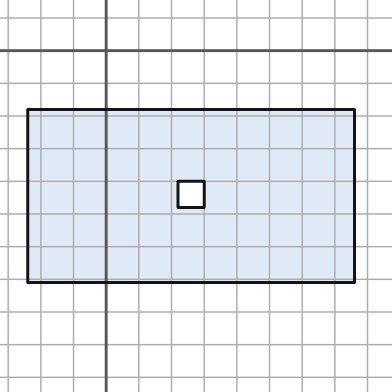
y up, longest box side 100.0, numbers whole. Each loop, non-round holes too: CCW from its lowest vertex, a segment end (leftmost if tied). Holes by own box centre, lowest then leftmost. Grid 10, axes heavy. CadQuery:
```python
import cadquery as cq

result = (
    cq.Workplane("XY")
    .moveTo(-24.0, -71.0)
    .lineTo(76.0, -71.0)
    .lineTo(76.0, -18.0)
    .lineTo(-24.0, -18.0)
    .close()
    .moveTo(22.0, -48.0)
    .lineTo(30.0, -48.0)
    .lineTo(30.0, -40.0)
    .lineTo(22.0, -40.0)
    .close()
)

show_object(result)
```